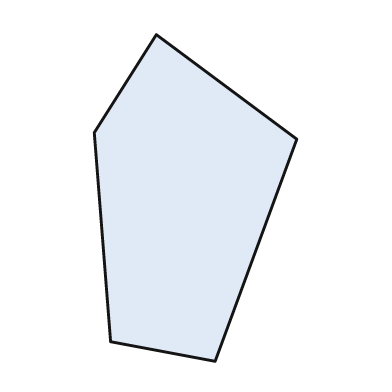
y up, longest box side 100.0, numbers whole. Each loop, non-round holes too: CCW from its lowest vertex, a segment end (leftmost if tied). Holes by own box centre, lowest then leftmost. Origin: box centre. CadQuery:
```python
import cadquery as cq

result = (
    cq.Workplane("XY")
    .moveTo(6.0, -50.0)
    .lineTo(31.0, 18.0)
    .lineTo(-12.0, 50.0)
    .lineTo(-31.0, 20.0)
    .lineTo(-26.0, -44.0)
    .close()
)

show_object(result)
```